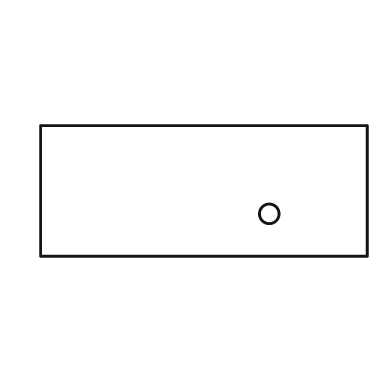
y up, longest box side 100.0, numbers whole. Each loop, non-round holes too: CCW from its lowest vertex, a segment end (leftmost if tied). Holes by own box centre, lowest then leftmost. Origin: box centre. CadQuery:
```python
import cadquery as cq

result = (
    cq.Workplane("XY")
    .moveTo(-50.0, -20.0)
    .lineTo(50.0, -20.0)
    .lineTo(50.0, 20.0)
    .lineTo(-50.0, 20.0)
    .close()
    .moveTo(20.0, -7.0)
    .circle(3.0)
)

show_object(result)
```